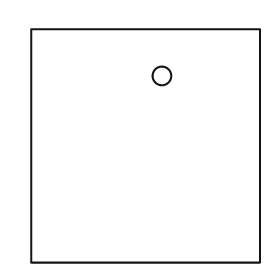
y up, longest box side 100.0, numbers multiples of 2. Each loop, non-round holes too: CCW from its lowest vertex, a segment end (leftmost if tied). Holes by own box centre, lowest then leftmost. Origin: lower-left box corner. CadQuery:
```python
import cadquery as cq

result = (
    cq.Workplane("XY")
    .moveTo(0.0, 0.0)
    .lineTo(98.0, 0.0)
    .lineTo(98.0, 100.0)
    .lineTo(0.0, 100.0)
    .close()
    .moveTo(56.0, 80.0)
    .circle(4.0)
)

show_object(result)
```